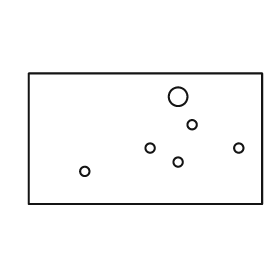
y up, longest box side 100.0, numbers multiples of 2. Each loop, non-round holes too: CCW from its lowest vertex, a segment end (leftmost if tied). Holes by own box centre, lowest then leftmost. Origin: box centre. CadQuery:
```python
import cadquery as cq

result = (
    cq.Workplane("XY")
    .moveTo(-50.0, -28.0)
    .lineTo(50.0, -28.0)
    .lineTo(50.0, 28.0)
    .lineTo(-50.0, 28.0)
    .close()
    .moveTo(-26.0, -14.0)
    .circle(2.0)
    .moveTo(14.0, -10.0)
    .circle(2.0)
    .moveTo(2.0, -4.0)
    .circle(2.0)
    .moveTo(40.0, -4.0)
    .circle(2.0)
    .moveTo(20.0, 6.0)
    .circle(2.0)
    .moveTo(14.0, 18.0)
    .circle(4.0)
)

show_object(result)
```